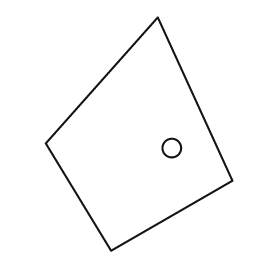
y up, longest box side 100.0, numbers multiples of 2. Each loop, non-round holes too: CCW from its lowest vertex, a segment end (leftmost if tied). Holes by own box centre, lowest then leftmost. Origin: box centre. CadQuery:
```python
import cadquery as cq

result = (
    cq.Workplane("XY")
    .moveTo(-12.0, -50.0)
    .lineTo(40.0, -20.0)
    .lineTo(8.0, 50.0)
    .lineTo(-40.0, -4.0)
    .close()
    .moveTo(14.0, -6.0)
    .circle(4.0)
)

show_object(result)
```